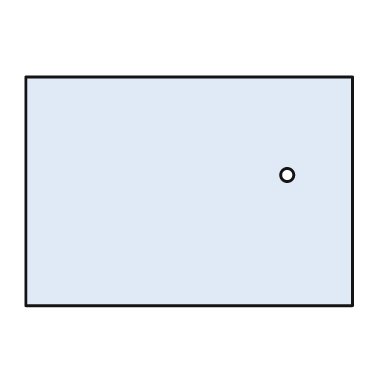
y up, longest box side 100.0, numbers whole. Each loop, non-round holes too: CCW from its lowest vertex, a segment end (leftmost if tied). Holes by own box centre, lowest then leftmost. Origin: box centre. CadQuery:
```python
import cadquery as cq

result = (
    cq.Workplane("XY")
    .moveTo(-50.0, -35.0)
    .lineTo(50.0, -35.0)
    .lineTo(50.0, 35.0)
    .lineTo(-50.0, 35.0)
    .close()
    .moveTo(30.0, 5.0)
    .circle(2.0)
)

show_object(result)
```